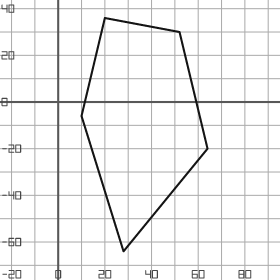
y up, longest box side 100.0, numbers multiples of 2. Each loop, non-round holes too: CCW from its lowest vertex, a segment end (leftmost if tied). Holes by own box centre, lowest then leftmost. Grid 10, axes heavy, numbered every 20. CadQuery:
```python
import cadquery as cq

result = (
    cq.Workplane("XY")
    .moveTo(28.0, -64.0)
    .lineTo(64.0, -20.0)
    .lineTo(52.0, 30.0)
    .lineTo(20.0, 36.0)
    .lineTo(10.0, -6.0)
    .close()
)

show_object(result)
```